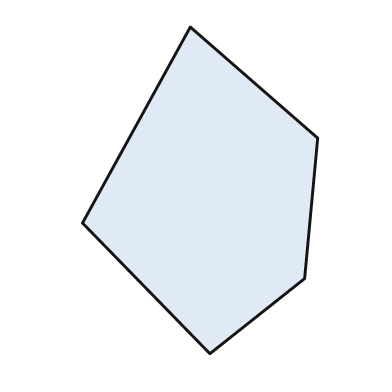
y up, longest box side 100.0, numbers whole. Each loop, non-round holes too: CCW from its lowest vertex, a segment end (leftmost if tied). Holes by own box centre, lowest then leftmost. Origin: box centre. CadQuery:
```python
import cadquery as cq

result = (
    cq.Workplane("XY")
    .moveTo(3.0, -50.0)
    .lineTo(32.0, -27.0)
    .lineTo(36.0, 16.0)
    .lineTo(-3.0, 50.0)
    .lineTo(-36.0, -10.0)
    .close()
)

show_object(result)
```